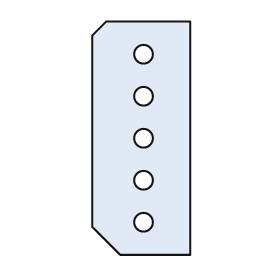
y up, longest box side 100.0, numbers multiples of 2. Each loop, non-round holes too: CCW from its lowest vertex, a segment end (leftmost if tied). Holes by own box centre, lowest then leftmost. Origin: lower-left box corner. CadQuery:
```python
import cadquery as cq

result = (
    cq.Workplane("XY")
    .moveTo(12.0, 0.0)
    .lineTo(42.0, 0.0)
    .lineTo(42.0, 100.0)
    .lineTo(6.0, 100.0)
    .lineTo(0.0, 94.0)
    .lineTo(0.0, 12.0)
    .close()
    .moveTo(22.0, 14.0)
    .circle(4.0)
    .moveTo(22.0, 32.0)
    .circle(4.0)
    .moveTo(22.0, 50.0)
    .circle(4.0)
    .moveTo(22.0, 68.0)
    .circle(4.0)
    .moveTo(22.0, 86.0)
    .circle(4.0)
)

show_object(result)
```